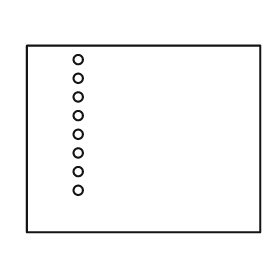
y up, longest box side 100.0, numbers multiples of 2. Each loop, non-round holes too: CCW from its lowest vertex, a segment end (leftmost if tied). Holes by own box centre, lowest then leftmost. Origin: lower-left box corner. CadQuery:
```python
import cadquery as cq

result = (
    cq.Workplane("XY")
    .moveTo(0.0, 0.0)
    .lineTo(100.0, 0.0)
    .lineTo(100.0, 80.0)
    .lineTo(0.0, 80.0)
    .close()
    .moveTo(22.0, 18.0)
    .circle(2.0)
    .moveTo(22.0, 26.0)
    .circle(2.0)
    .moveTo(22.0, 34.0)
    .circle(2.0)
    .moveTo(22.0, 42.0)
    .circle(2.0)
    .moveTo(22.0, 50.0)
    .circle(2.0)
    .moveTo(22.0, 58.0)
    .circle(2.0)
    .moveTo(22.0, 66.0)
    .circle(2.0)
    .moveTo(22.0, 74.0)
    .circle(2.0)
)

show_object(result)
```